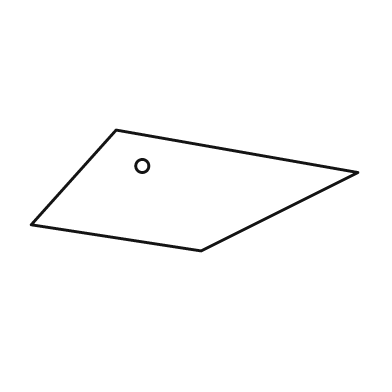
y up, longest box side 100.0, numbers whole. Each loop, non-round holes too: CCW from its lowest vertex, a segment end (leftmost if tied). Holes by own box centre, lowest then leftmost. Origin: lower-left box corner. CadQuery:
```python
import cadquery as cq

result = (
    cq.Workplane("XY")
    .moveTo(52.0, 0.0)
    .lineTo(100.0, 24.0)
    .lineTo(26.0, 37.0)
    .lineTo(0.0, 8.0)
    .close()
    .moveTo(34.0, 26.0)
    .circle(2.0)
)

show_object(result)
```